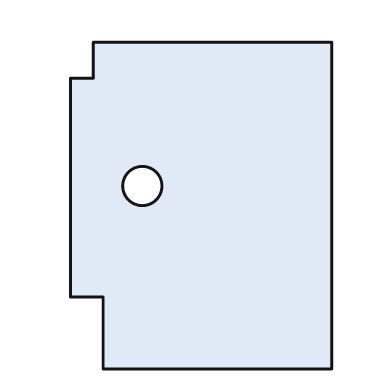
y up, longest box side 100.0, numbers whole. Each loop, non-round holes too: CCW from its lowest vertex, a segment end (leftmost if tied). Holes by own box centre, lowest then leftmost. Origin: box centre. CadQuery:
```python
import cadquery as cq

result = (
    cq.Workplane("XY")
    .moveTo(-30.0, -50.0)
    .lineTo(40.0, -50.0)
    .lineTo(40.0, 50.0)
    .lineTo(-33.0, 50.0)
    .lineTo(-33.0, 39.0)
    .lineTo(-40.0, 39.0)
    .lineTo(-40.0, -28.0)
    .lineTo(-30.0, -28.0)
    .close()
    .moveTo(-18.0, 6.0)
    .circle(6.0)
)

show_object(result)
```